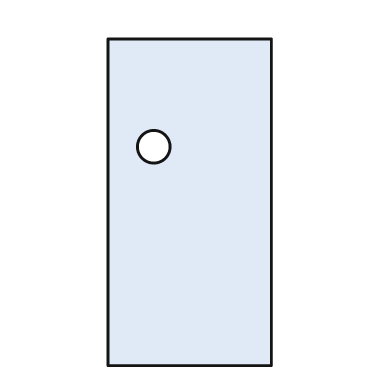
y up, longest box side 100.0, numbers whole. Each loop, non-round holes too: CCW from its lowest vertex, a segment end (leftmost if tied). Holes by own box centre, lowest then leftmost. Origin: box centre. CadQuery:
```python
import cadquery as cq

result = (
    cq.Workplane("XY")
    .moveTo(-25.0, -50.0)
    .lineTo(25.0, -50.0)
    .lineTo(25.0, 50.0)
    .lineTo(-25.0, 50.0)
    .close()
    .moveTo(-11.0, 17.0)
    .circle(5.0)
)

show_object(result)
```